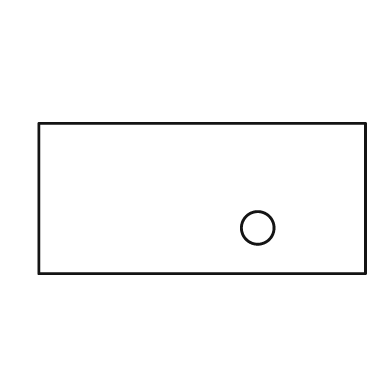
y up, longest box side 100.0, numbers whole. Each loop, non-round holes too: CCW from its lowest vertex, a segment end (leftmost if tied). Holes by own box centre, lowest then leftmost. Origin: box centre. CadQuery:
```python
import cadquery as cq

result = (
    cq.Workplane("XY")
    .moveTo(-50.0, -23.0)
    .lineTo(50.0, -23.0)
    .lineTo(50.0, 23.0)
    .lineTo(-50.0, 23.0)
    .close()
    .moveTo(17.0, -9.0)
    .circle(5.0)
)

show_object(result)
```